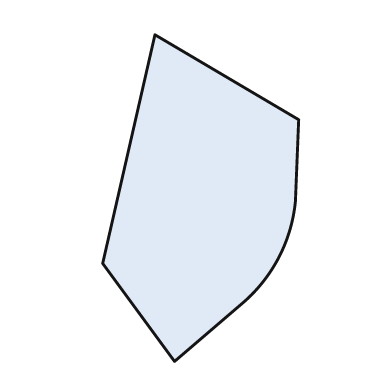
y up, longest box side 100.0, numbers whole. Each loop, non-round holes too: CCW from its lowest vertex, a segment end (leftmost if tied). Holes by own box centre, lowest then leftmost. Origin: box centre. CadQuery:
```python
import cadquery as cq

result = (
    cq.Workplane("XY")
    .moveTo(-8.0, -50.0)
    .lineTo(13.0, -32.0)
    .threePointArc((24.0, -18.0), (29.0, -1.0))
    .lineTo(30.0, 24.0)
    .lineTo(-14.0, 50.0)
    .lineTo(-30.0, -20.0)
    .close()
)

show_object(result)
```